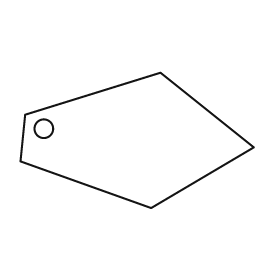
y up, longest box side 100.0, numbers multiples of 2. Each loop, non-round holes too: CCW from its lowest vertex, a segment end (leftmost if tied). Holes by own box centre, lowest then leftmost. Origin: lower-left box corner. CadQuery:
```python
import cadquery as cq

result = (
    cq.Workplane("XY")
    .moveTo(56.0, 0.0)
    .lineTo(100.0, 26.0)
    .lineTo(60.0, 58.0)
    .lineTo(2.0, 40.0)
    .lineTo(0.0, 20.0)
    .close()
    .moveTo(10.0, 34.0)
    .circle(4.0)
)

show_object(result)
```